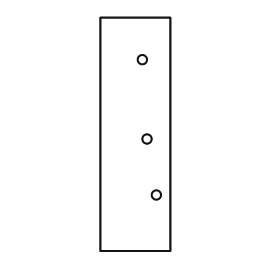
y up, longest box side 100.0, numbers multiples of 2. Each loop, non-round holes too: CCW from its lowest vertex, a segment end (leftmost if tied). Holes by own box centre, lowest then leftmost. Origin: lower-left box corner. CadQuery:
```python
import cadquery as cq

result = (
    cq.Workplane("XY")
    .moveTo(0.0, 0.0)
    .lineTo(30.0, 0.0)
    .lineTo(30.0, 100.0)
    .lineTo(0.0, 100.0)
    .close()
    .moveTo(24.0, 24.0)
    .circle(2.0)
    .moveTo(20.0, 48.0)
    .circle(2.0)
    .moveTo(18.0, 82.0)
    .circle(2.0)
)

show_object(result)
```